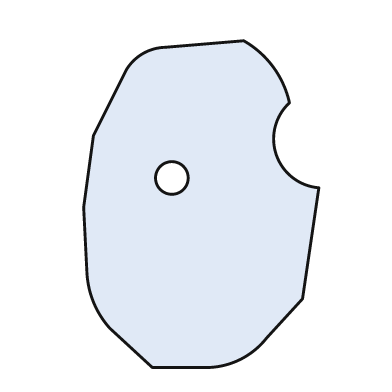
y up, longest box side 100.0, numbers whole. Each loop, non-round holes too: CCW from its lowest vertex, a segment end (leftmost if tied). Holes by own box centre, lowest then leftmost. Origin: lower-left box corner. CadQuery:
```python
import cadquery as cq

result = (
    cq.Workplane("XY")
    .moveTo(21.0, 0.0)
    .lineTo(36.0, 0.0)
    .threePointArc((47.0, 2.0), (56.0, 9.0))
    .lineTo(67.0, 21.0)
    .lineTo(72.0, 55.0)
    .threePointArc((59.0, 65.0), (63.0, 81.0))
    .threePointArc((58.0, 92.0), (49.0, 100.0))
    .lineTo(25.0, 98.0)
    .threePointArc((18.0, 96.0), (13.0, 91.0))
    .lineTo(3.0, 71.0)
    .lineTo(0.0, 49.0)
    .lineTo(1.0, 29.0)
    .threePointArc((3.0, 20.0), (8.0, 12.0))
    .close()
    .moveTo(27.0, 58.0)
    .circle(5.0)
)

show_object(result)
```